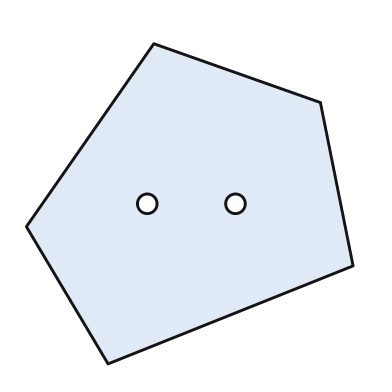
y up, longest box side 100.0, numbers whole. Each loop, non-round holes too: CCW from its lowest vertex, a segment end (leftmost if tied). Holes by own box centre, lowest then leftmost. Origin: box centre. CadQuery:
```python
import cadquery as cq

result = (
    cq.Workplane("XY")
    .moveTo(-25.0, -49.0)
    .lineTo(50.0, -19.0)
    .lineTo(40.0, 31.0)
    .lineTo(-11.0, 49.0)
    .lineTo(-50.0, -7.0)
    .close()
    .moveTo(-13.0, 0.0)
    .circle(3.0)
    .moveTo(14.0, 0.0)
    .circle(3.0)
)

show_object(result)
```